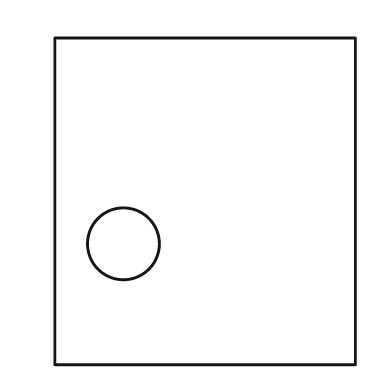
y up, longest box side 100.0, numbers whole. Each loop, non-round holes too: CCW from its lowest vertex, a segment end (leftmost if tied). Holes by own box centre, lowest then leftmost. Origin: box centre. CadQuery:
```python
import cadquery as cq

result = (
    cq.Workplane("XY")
    .moveTo(-46.0, -50.0)
    .lineTo(46.0, -50.0)
    .lineTo(46.0, 50.0)
    .lineTo(-46.0, 50.0)
    .close()
    .moveTo(-25.0, -13.0)
    .circle(11.0)
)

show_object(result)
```